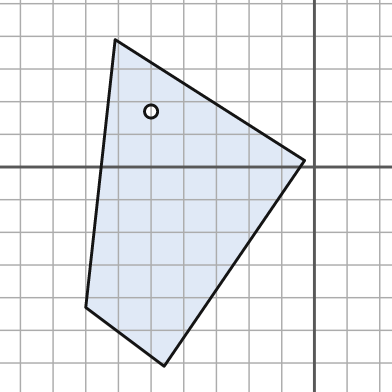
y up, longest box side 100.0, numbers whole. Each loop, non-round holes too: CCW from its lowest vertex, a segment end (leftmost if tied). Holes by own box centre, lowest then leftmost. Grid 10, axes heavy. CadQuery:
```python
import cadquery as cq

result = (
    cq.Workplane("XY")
    .moveTo(-46.0, -61.0)
    .lineTo(-3.0, 2.0)
    .lineTo(-61.0, 39.0)
    .lineTo(-70.0, -43.0)
    .close()
    .moveTo(-50.0, 17.0)
    .circle(2.0)
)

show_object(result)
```